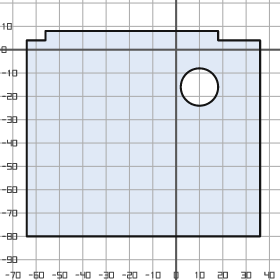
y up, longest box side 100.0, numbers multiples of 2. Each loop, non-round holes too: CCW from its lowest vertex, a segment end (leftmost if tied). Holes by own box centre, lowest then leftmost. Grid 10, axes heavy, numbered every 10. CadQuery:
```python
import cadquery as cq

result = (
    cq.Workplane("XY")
    .moveTo(-64.0, -80.0)
    .lineTo(36.0, -80.0)
    .lineTo(36.0, 4.0)
    .lineTo(18.0, 4.0)
    .lineTo(18.0, 8.0)
    .lineTo(-56.0, 8.0)
    .lineTo(-56.0, 4.0)
    .lineTo(-64.0, 4.0)
    .close()
    .moveTo(10.0, -16.0)
    .circle(8.0)
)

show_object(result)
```